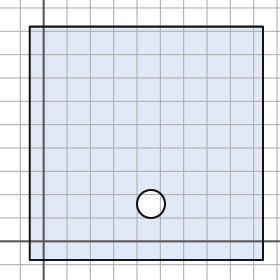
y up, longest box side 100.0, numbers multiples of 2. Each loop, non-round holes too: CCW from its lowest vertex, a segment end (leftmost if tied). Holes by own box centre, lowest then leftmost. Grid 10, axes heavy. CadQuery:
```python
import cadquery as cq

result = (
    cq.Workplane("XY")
    .moveTo(-6.0, -8.0)
    .lineTo(94.0, -8.0)
    .lineTo(94.0, 92.0)
    .lineTo(-6.0, 92.0)
    .close()
    .moveTo(46.0, 16.0)
    .circle(6.0)
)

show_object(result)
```